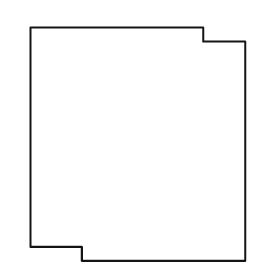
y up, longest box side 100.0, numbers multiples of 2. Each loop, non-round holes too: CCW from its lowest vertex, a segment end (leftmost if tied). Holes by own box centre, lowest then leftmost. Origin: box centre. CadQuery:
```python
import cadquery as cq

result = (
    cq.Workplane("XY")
    .moveTo(-24.0, -50.0)
    .lineTo(46.0, -50.0)
    .lineTo(46.0, 44.0)
    .lineTo(28.0, 44.0)
    .lineTo(28.0, 50.0)
    .lineTo(-46.0, 50.0)
    .lineTo(-46.0, -44.0)
    .lineTo(-24.0, -44.0)
    .close()
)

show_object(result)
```